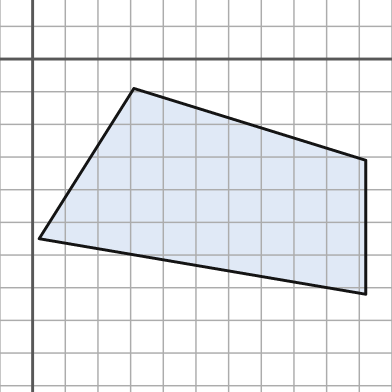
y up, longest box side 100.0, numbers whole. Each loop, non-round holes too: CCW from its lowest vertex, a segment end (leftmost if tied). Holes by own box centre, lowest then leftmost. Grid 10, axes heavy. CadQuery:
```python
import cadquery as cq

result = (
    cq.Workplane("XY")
    .moveTo(102.0, -72.0)
    .lineTo(102.0, -31.0)
    .lineTo(31.0, -9.0)
    .lineTo(2.0, -55.0)
    .close()
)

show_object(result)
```